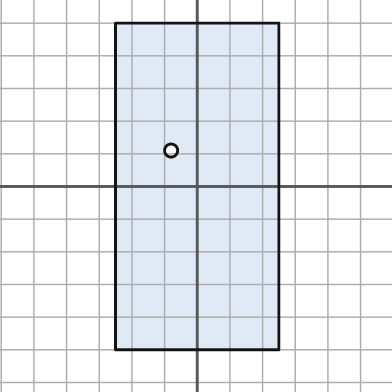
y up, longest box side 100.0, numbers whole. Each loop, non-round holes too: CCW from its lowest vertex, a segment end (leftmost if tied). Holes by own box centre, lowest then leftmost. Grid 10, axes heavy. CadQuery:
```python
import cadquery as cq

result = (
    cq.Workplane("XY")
    .moveTo(-25.0, -50.0)
    .lineTo(25.0, -50.0)
    .lineTo(25.0, 50.0)
    .lineTo(-25.0, 50.0)
    .close()
    .moveTo(-8.0, 11.0)
    .circle(2.0)
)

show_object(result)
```